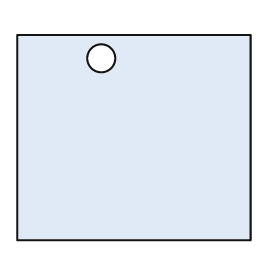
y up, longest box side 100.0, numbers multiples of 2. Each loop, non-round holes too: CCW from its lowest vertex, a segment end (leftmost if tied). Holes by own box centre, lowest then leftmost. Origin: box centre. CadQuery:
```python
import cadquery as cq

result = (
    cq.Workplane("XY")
    .moveTo(-50.0, -44.0)
    .lineTo(50.0, -44.0)
    .lineTo(50.0, 44.0)
    .lineTo(-50.0, 44.0)
    .close()
    .moveTo(-14.0, 34.0)
    .circle(6.0)
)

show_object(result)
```